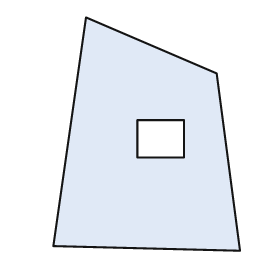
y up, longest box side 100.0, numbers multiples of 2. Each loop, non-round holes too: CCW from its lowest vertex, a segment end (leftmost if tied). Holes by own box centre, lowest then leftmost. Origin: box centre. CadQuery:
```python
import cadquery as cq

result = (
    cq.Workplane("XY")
    .moveTo(40.0, -50.0)
    .lineTo(30.0, 26.0)
    .lineTo(-26.0, 50.0)
    .lineTo(-40.0, -48.0)
    .close()
    .moveTo(-4.0, -10.0)
    .lineTo(16.0, -10.0)
    .lineTo(16.0, 6.0)
    .lineTo(-4.0, 6.0)
    .close()
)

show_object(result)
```